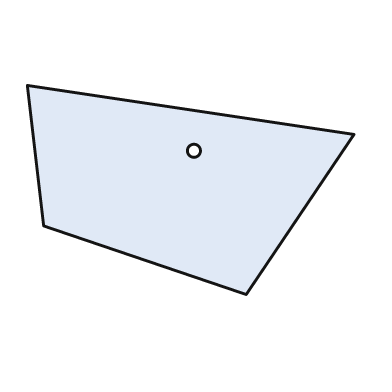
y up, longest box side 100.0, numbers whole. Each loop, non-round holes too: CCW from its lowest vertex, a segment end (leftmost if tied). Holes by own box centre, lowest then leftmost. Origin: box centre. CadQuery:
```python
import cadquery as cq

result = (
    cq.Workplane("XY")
    .moveTo(17.0, -32.0)
    .lineTo(50.0, 17.0)
    .lineTo(-50.0, 32.0)
    .lineTo(-45.0, -11.0)
    .close()
    .moveTo(1.0, 12.0)
    .circle(2.0)
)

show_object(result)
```